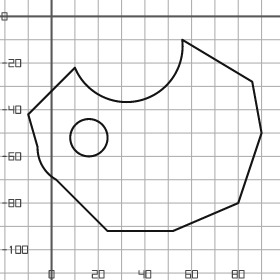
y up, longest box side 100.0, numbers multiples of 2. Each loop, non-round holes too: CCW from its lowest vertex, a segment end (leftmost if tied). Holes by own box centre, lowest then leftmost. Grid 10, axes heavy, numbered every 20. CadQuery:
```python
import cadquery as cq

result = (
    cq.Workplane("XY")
    .moveTo(24.0, -92.0)
    .lineTo(52.0, -92.0)
    .lineTo(80.0, -80.0)
    .lineTo(90.0, -50.0)
    .lineTo(86.0, -28.0)
    .lineTo(56.0, -10.0)
    .threePointArc((38.0, -36.0), (10.0, -22.0))
    .lineTo(-10.0, -42.0)
    .lineTo(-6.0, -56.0)
    .threePointArc((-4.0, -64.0), (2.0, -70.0))
    .close()
    .moveTo(16.0, -52.0)
    .circle(8.0)
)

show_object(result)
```